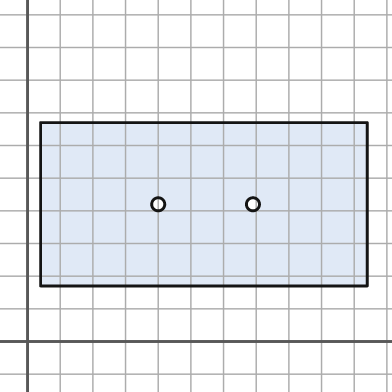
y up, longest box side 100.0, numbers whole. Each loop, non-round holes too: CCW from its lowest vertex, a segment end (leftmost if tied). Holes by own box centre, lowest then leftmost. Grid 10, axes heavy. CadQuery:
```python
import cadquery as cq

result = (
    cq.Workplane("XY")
    .moveTo(4.0, 17.0)
    .lineTo(104.0, 17.0)
    .lineTo(104.0, 67.0)
    .lineTo(4.0, 67.0)
    .close()
    .moveTo(40.0, 42.0)
    .circle(2.0)
    .moveTo(69.0, 42.0)
    .circle(2.0)
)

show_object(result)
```